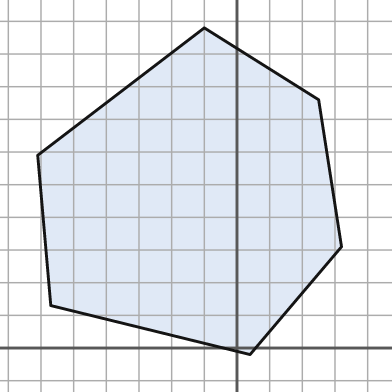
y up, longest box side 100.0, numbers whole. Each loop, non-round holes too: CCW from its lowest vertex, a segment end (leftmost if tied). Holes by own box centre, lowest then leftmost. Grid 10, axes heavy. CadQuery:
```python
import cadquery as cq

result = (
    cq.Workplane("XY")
    .moveTo(4.0, -2.0)
    .lineTo(32.0, 31.0)
    .lineTo(25.0, 76.0)
    .lineTo(-10.0, 98.0)
    .lineTo(-61.0, 59.0)
    .lineTo(-57.0, 13.0)
    .close()
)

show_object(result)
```